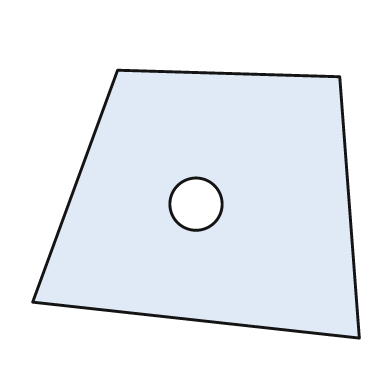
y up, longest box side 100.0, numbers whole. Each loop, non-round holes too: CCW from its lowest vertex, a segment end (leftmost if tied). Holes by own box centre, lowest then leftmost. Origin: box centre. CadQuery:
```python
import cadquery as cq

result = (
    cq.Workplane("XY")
    .moveTo(50.0, -41.0)
    .lineTo(44.0, 39.0)
    .lineTo(-24.0, 41.0)
    .lineTo(-50.0, -30.0)
    .close()
    .moveTo(0.0, 0.0)
    .circle(8.0)
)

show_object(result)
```